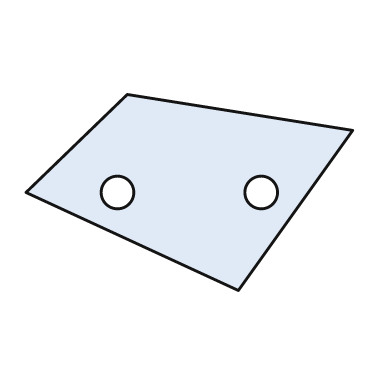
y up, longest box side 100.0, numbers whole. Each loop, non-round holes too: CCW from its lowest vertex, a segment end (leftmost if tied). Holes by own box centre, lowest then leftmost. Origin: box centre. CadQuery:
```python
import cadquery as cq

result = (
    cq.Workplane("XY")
    .moveTo(15.0, -30.0)
    .lineTo(50.0, 19.0)
    .lineTo(-19.0, 30.0)
    .lineTo(-50.0, 0.0)
    .close()
    .moveTo(-22.0, 0.0)
    .circle(5.0)
    .moveTo(22.0, 0.0)
    .circle(5.0)
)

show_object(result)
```